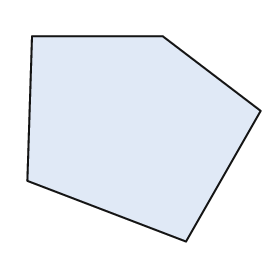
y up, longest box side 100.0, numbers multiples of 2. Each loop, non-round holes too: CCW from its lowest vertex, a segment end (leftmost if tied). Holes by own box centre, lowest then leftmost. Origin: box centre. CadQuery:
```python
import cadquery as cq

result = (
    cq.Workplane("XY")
    .moveTo(18.0, -44.0)
    .lineTo(50.0, 12.0)
    .lineTo(8.0, 44.0)
    .lineTo(-48.0, 44.0)
    .lineTo(-50.0, -18.0)
    .close()
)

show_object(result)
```